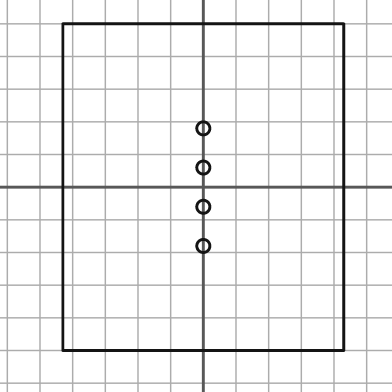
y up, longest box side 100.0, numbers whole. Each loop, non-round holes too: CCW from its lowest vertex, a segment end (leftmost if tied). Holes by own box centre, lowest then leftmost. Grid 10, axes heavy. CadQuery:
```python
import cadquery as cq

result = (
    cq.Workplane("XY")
    .moveTo(-43.0, -50.0)
    .lineTo(43.0, -50.0)
    .lineTo(43.0, 50.0)
    .lineTo(-43.0, 50.0)
    .close()
    .moveTo(0.0, -18.0)
    .circle(2.0)
    .moveTo(0.0, -6.0)
    .circle(2.0)
    .moveTo(0.0, 6.0)
    .circle(2.0)
    .moveTo(0.0, 18.0)
    .circle(2.0)
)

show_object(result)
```